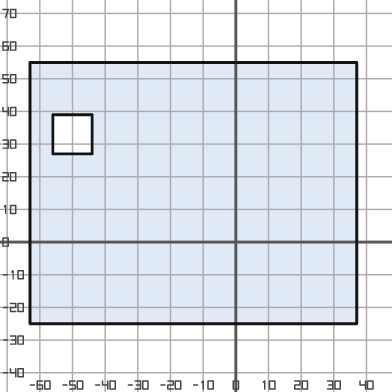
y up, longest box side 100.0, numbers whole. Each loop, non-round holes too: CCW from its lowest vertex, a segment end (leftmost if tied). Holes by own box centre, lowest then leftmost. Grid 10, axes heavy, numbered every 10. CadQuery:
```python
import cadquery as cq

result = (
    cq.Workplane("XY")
    .moveTo(-63.0, -25.0)
    .lineTo(37.0, -25.0)
    .lineTo(37.0, 55.0)
    .lineTo(-63.0, 55.0)
    .close()
    .moveTo(-56.0, 27.0)
    .lineTo(-44.0, 27.0)
    .lineTo(-44.0, 39.0)
    .lineTo(-56.0, 39.0)
    .close()
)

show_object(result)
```